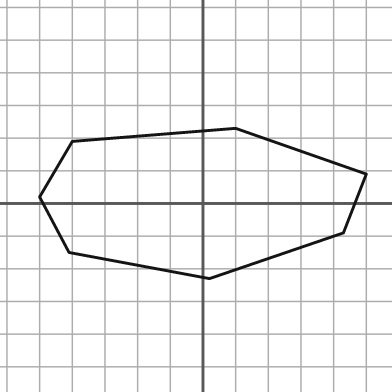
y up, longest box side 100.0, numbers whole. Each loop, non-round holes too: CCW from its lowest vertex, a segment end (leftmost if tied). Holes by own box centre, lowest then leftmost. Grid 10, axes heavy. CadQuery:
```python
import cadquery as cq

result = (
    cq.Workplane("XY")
    .moveTo(2.0, -23.0)
    .lineTo(43.0, -9.0)
    .lineTo(50.0, 9.0)
    .lineTo(10.0, 23.0)
    .lineTo(-40.0, 19.0)
    .lineTo(-50.0, 2.0)
    .lineTo(-41.0, -15.0)
    .close()
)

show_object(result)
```